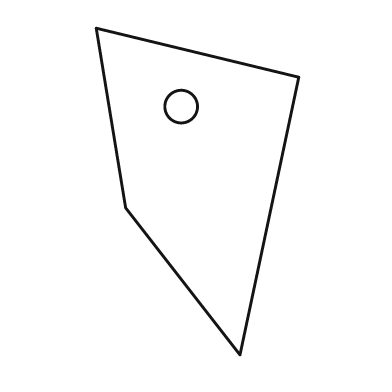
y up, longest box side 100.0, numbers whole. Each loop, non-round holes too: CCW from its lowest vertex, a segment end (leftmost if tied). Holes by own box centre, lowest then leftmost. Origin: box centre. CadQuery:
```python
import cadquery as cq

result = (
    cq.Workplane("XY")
    .moveTo(13.0, -50.0)
    .lineTo(31.0, 35.0)
    .lineTo(-31.0, 50.0)
    .lineTo(-22.0, -5.0)
    .close()
    .moveTo(-5.0, 26.0)
    .circle(5.0)
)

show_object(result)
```